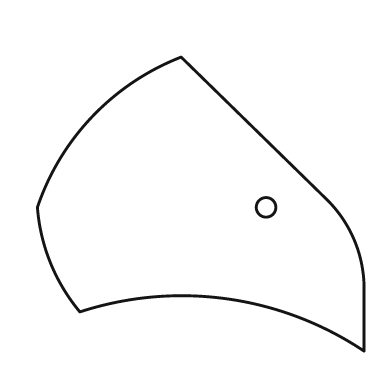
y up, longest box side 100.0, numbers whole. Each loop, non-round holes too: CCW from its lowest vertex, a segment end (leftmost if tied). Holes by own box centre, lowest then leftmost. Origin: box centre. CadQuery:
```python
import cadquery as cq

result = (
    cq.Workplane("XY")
    .moveTo(50.0, -45.0)
    .lineTo(50.0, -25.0)
    .threePointArc((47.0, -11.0), (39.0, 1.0))
    .lineTo(-6.0, 45.0)
    .threePointArc((-33.0, 27.0), (-50.0, -1.0))
    .threePointArc((-46.0, -18.0), (-37.0, -33.0))
    .threePointArc((8.0, -29.0), (50.0, -45.0))
    .close()
    .moveTo(20.0, -1.0)
    .circle(3.0)
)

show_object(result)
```